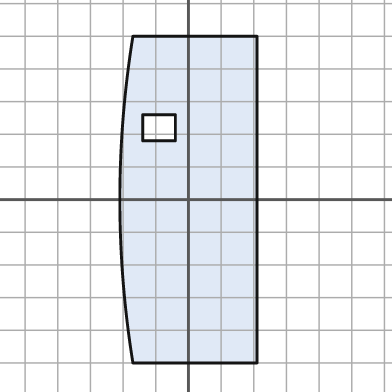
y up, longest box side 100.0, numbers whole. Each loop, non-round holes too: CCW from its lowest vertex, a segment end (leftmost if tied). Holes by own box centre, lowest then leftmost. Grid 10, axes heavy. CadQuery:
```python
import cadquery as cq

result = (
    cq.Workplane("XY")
    .moveTo(-17.0, -50.0)
    .lineTo(21.0, -50.0)
    .lineTo(21.0, 50.0)
    .lineTo(-17.0, 50.0)
    .threePointArc((-21.0, 0.0), (-17.0, -50.0))
    .close()
    .moveTo(-14.0, 18.0)
    .lineTo(-4.0, 18.0)
    .lineTo(-4.0, 26.0)
    .lineTo(-14.0, 26.0)
    .close()
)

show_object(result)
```